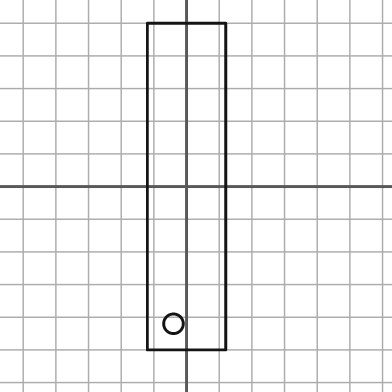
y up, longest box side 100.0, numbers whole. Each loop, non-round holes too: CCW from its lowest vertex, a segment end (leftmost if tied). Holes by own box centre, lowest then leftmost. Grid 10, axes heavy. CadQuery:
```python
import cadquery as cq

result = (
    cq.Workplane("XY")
    .moveTo(-12.0, -50.0)
    .lineTo(12.0, -50.0)
    .lineTo(12.0, 50.0)
    .lineTo(-12.0, 50.0)
    .close()
    .moveTo(-4.0, -42.0)
    .circle(3.0)
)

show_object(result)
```